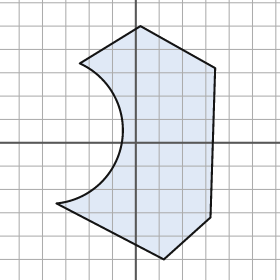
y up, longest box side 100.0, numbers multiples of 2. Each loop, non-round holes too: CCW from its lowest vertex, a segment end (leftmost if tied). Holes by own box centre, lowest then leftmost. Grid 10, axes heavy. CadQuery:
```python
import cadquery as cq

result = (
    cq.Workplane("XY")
    .moveTo(12.0, -50.0)
    .lineTo(32.0, -32.0)
    .lineTo(34.0, 32.0)
    .lineTo(2.0, 50.0)
    .lineTo(-24.0, 34.0)
    .threePointArc((-6.0, 0.0), (-34.0, -26.0))
    .close()
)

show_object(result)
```